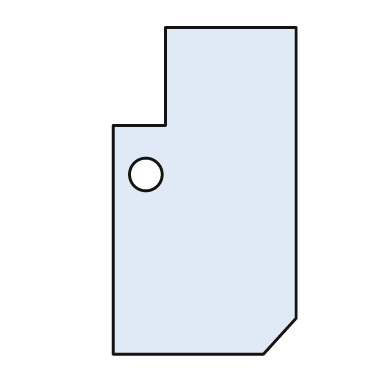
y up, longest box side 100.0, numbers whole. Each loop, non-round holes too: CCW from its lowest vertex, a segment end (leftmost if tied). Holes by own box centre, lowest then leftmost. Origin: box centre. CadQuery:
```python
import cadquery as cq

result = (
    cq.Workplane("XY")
    .moveTo(-28.0, -50.0)
    .lineTo(18.0, -50.0)
    .lineTo(28.0, -39.0)
    .lineTo(28.0, 50.0)
    .lineTo(-12.0, 50.0)
    .lineTo(-12.0, 20.0)
    .lineTo(-28.0, 20.0)
    .close()
    .moveTo(-18.0, 5.0)
    .circle(5.0)
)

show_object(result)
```